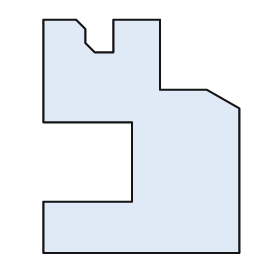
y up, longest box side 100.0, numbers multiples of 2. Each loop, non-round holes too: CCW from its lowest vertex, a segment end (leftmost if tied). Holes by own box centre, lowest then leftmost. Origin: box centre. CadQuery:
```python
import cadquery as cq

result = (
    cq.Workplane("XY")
    .moveTo(-42.0, -50.0)
    .lineTo(42.0, -50.0)
    .lineTo(42.0, 12.0)
    .lineTo(28.0, 20.0)
    .lineTo(8.0, 20.0)
    .lineTo(8.0, 50.0)
    .lineTo(-12.0, 50.0)
    .lineTo(-12.0, 36.0)
    .lineTo(-20.0, 36.0)
    .lineTo(-24.0, 40.0)
    .lineTo(-24.0, 46.0)
    .lineTo(-28.0, 50.0)
    .lineTo(-42.0, 50.0)
    .lineTo(-42.0, 6.0)
    .lineTo(-4.0, 6.0)
    .lineTo(-4.0, -28.0)
    .lineTo(-42.0, -28.0)
    .close()
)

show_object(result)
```